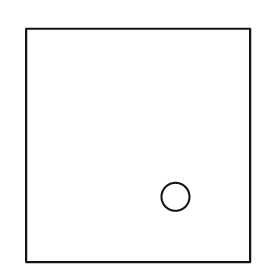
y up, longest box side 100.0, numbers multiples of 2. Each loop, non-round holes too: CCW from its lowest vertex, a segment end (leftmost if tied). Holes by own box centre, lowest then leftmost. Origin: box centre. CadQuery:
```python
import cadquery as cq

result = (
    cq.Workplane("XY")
    .moveTo(-48.0, -50.0)
    .lineTo(48.0, -50.0)
    .lineTo(48.0, 50.0)
    .lineTo(-48.0, 50.0)
    .close()
    .moveTo(16.0, -22.0)
    .circle(6.0)
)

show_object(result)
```